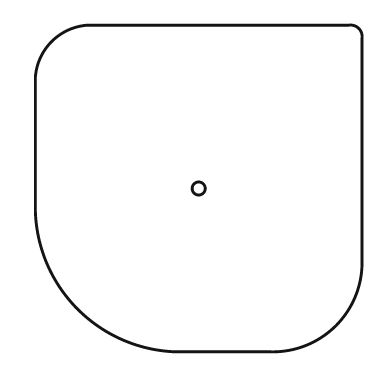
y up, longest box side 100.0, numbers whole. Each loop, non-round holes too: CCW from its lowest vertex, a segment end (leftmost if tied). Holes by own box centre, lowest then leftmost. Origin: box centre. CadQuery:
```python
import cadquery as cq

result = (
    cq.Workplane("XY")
    .moveTo(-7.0, -50.0)
    .lineTo(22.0, -50.0)
    .threePointArc((42.0, -42.0), (50.0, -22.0))
    .lineTo(50.0, 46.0)
    .threePointArc((49.0, 49.0), (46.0, 50.0))
    .lineTo(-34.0, 50.0)
    .threePointArc((-45.0, 45.0), (-50.0, 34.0))
    .lineTo(-50.0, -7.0)
    .threePointArc((-37.0, -37.0), (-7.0, -50.0))
    .close()
    .moveTo(0.0, 0.0)
    .circle(2.0)
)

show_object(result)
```